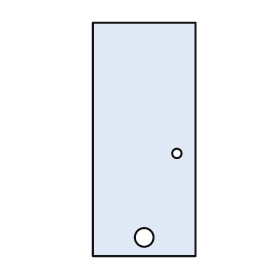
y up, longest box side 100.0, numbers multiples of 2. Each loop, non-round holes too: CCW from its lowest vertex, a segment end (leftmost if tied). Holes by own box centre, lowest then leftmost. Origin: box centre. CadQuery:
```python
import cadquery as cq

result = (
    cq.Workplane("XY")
    .moveTo(-22.0, -50.0)
    .lineTo(22.0, -50.0)
    .lineTo(22.0, 50.0)
    .lineTo(-22.0, 50.0)
    .close()
    .moveTo(0.0, -42.0)
    .circle(4.0)
    .moveTo(14.0, -6.0)
    .circle(2.0)
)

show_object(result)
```